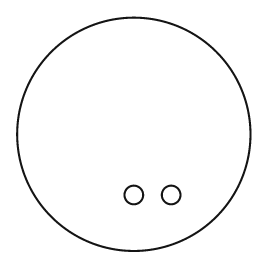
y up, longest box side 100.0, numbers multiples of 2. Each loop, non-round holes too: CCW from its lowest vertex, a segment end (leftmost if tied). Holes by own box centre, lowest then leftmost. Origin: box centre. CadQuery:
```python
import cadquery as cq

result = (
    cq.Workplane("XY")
    .moveTo(0.0, 0.0)
    .circle(50.0)
    .moveTo(0.0, -26.0)
    .circle(4.0)
    .moveTo(16.0, -26.0)
    .circle(4.0)
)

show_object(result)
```